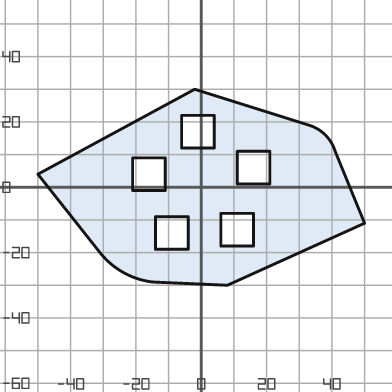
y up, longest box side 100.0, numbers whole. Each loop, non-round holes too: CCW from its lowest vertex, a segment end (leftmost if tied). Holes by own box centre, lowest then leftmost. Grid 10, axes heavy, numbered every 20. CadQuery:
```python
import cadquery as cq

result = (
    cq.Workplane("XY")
    .moveTo(8.0, -30.0)
    .lineTo(50.0, -11.0)
    .lineTo(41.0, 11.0)
    .threePointArc((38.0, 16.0), (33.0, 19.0))
    .lineTo(-2.0, 30.0)
    .lineTo(-50.0, 4.0)
    .lineTo(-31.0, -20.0)
    .threePointArc((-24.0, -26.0), (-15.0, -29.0))
    .close()
    .moveTo(-14.0, -19.0)
    .lineTo(-4.0, -19.0)
    .lineTo(-4.0, -9.0)
    .lineTo(-14.0, -9.0)
    .close()
    .moveTo(6.0, -18.0)
    .lineTo(16.0, -18.0)
    .lineTo(16.0, -8.0)
    .lineTo(6.0, -8.0)
    .close()
    .moveTo(-21.0, -1.0)
    .lineTo(-11.0, -1.0)
    .lineTo(-11.0, 9.0)
    .lineTo(-21.0, 9.0)
    .close()
    .moveTo(11.0, 1.0)
    .lineTo(21.0, 1.0)
    .lineTo(21.0, 11.0)
    .lineTo(11.0, 11.0)
    .close()
    .moveTo(-6.0, 12.0)
    .lineTo(4.0, 12.0)
    .lineTo(4.0, 22.0)
    .lineTo(-6.0, 22.0)
    .close()
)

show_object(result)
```